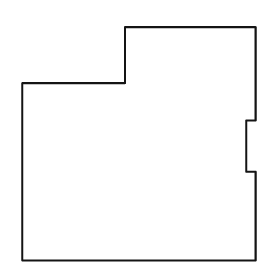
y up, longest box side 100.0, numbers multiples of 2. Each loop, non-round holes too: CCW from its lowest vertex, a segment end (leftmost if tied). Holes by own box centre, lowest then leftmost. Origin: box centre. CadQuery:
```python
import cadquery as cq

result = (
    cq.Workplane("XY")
    .moveTo(-50.0, -50.0)
    .lineTo(50.0, -50.0)
    .lineTo(50.0, -12.0)
    .lineTo(46.0, -12.0)
    .lineTo(46.0, 10.0)
    .lineTo(50.0, 10.0)
    .lineTo(50.0, 50.0)
    .lineTo(-6.0, 50.0)
    .lineTo(-6.0, 26.0)
    .lineTo(-50.0, 26.0)
    .close()
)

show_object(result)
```